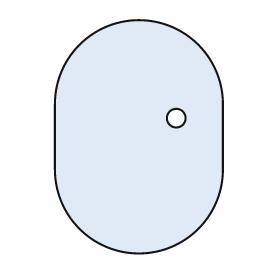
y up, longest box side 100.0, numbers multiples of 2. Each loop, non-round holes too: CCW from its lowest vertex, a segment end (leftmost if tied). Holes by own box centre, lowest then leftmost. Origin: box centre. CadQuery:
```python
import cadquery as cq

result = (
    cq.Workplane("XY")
    .moveTo(-36.0, -14.0)
    .threePointArc((0.0, -50.0), (36.0, -14.0))
    .lineTo(36.0, 14.0)
    .threePointArc((0.0, 50.0), (-36.0, 14.0))
    .close()
    .moveTo(16.0, 8.0)
    .circle(4.0)
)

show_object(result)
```